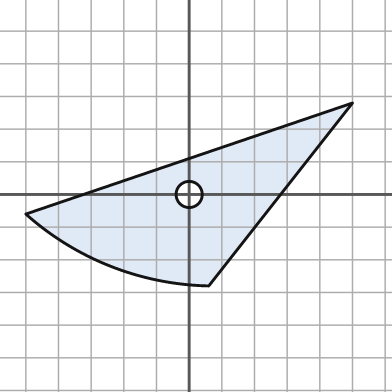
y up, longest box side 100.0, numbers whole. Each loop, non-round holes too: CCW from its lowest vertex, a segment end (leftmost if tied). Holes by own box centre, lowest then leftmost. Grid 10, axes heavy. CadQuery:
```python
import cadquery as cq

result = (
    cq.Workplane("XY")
    .moveTo(6.0, -28.0)
    .lineTo(50.0, 28.0)
    .lineTo(-50.0, -6.0)
    .threePointArc((-24.0, -22.0), (6.0, -28.0))
    .close()
    .moveTo(0.0, 0.0)
    .circle(4.0)
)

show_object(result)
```